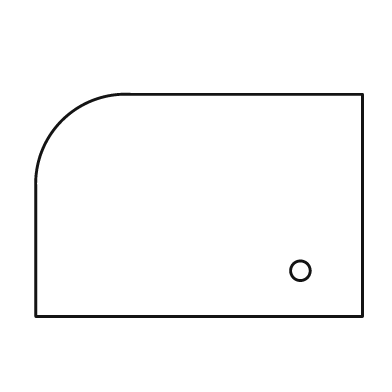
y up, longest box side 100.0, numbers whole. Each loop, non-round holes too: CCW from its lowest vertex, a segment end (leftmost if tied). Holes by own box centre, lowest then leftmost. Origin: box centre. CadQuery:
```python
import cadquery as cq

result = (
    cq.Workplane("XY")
    .moveTo(-50.0, -34.0)
    .lineTo(50.0, -34.0)
    .lineTo(50.0, 34.0)
    .lineTo(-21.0, 34.0)
    .threePointArc((-42.0, 26.0), (-50.0, 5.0))
    .close()
    .moveTo(31.0, -20.0)
    .circle(3.0)
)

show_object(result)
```